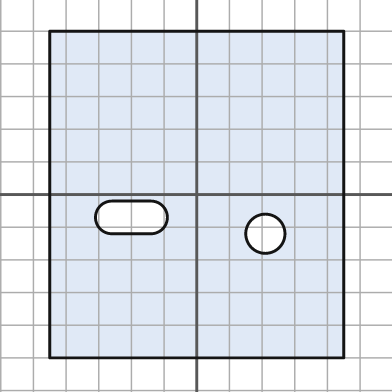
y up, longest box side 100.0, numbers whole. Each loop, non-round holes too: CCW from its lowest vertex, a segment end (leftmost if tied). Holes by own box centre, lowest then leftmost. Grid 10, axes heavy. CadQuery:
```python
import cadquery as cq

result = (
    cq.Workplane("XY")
    .moveTo(-45.0, -50.0)
    .lineTo(45.0, -50.0)
    .lineTo(45.0, 50.0)
    .lineTo(-45.0, 50.0)
    .close()
    .moveTo(21.0, -12.0)
    .circle(6.0)
    .moveTo(-26.0, -12.0)
    .lineTo(-14.0, -12.0)
    .threePointArc((-9.0, -7.0), (-14.0, -2.0))
    .lineTo(-26.0, -2.0)
    .threePointArc((-31.0, -7.0), (-26.0, -12.0))
    .close()
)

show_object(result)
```